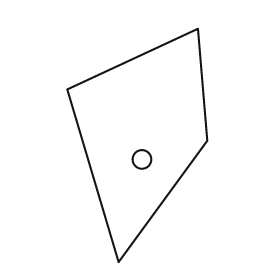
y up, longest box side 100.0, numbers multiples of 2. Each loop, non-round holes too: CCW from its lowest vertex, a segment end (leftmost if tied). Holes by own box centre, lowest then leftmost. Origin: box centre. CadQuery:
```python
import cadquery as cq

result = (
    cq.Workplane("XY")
    .moveTo(-8.0, -50.0)
    .lineTo(30.0, 2.0)
    .lineTo(26.0, 50.0)
    .lineTo(-30.0, 24.0)
    .close()
    .moveTo(2.0, -6.0)
    .circle(4.0)
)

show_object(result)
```